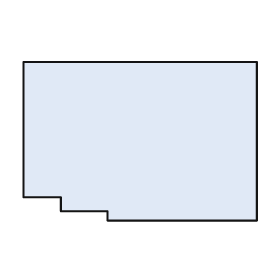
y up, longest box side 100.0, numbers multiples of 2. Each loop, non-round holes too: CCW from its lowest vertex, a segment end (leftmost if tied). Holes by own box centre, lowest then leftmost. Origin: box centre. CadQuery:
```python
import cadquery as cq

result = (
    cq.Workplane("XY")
    .moveTo(-14.0, -34.0)
    .lineTo(50.0, -34.0)
    .lineTo(50.0, 34.0)
    .lineTo(-50.0, 34.0)
    .lineTo(-50.0, -24.0)
    .lineTo(-34.0, -24.0)
    .lineTo(-34.0, -30.0)
    .lineTo(-14.0, -30.0)
    .close()
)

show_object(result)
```